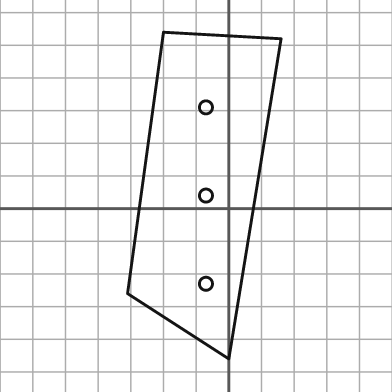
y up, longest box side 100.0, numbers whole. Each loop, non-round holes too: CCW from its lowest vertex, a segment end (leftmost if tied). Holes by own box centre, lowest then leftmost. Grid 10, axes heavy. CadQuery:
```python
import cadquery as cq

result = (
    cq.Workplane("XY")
    .moveTo(0.0, -46.0)
    .lineTo(16.0, 52.0)
    .lineTo(-20.0, 54.0)
    .lineTo(-31.0, -26.0)
    .close()
    .moveTo(-7.0, -23.0)
    .circle(2.0)
    .moveTo(-7.0, 4.0)
    .circle(2.0)
    .moveTo(-7.0, 31.0)
    .circle(2.0)
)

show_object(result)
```